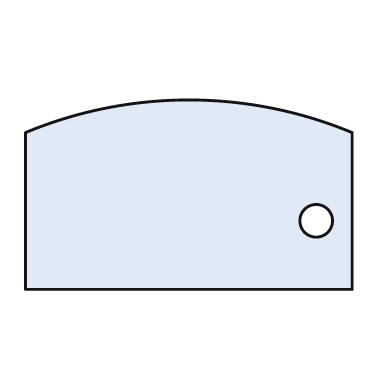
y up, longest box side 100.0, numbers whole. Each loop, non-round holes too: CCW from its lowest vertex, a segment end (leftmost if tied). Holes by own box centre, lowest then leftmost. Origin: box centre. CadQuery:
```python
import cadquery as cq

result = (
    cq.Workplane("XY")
    .moveTo(-50.0, -29.0)
    .lineTo(50.0, -29.0)
    .lineTo(50.0, 19.0)
    .threePointArc((0.0, 29.0), (-50.0, 19.0))
    .close()
    .moveTo(39.0, -8.0)
    .circle(5.0)
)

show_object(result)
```